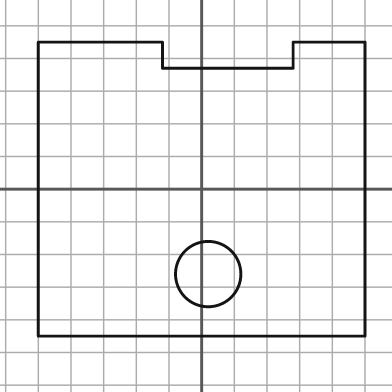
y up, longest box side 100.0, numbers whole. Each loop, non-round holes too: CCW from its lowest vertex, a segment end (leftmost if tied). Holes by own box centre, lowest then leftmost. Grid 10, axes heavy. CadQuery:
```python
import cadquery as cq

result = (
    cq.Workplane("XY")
    .moveTo(-50.0, -45.0)
    .lineTo(50.0, -45.0)
    .lineTo(50.0, 45.0)
    .lineTo(28.0, 45.0)
    .lineTo(28.0, 37.0)
    .lineTo(-12.0, 37.0)
    .lineTo(-12.0, 45.0)
    .lineTo(-50.0, 45.0)
    .close()
    .moveTo(2.0, -26.0)
    .circle(10.0)
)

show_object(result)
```